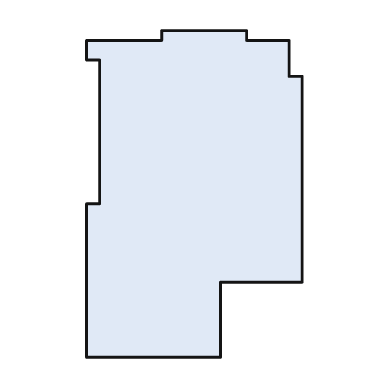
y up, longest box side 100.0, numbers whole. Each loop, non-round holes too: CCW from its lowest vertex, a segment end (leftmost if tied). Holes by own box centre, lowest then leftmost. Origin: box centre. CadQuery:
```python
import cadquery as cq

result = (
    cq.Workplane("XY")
    .moveTo(-33.0, -50.0)
    .lineTo(8.0, -50.0)
    .lineTo(8.0, -27.0)
    .lineTo(33.0, -27.0)
    .lineTo(33.0, 36.0)
    .lineTo(29.0, 36.0)
    .lineTo(29.0, 47.0)
    .lineTo(16.0, 47.0)
    .lineTo(16.0, 50.0)
    .lineTo(-10.0, 50.0)
    .lineTo(-10.0, 47.0)
    .lineTo(-33.0, 47.0)
    .lineTo(-33.0, 41.0)
    .lineTo(-29.0, 41.0)
    .lineTo(-29.0, -3.0)
    .lineTo(-33.0, -3.0)
    .close()
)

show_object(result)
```